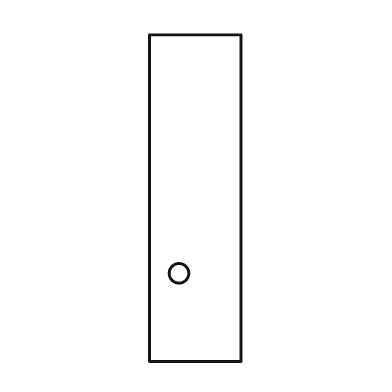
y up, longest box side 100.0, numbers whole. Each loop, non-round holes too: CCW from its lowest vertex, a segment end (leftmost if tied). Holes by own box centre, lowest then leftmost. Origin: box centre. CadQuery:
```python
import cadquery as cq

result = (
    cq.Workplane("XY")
    .moveTo(-14.0, -50.0)
    .lineTo(14.0, -50.0)
    .lineTo(14.0, 50.0)
    .lineTo(-14.0, 50.0)
    .close()
    .moveTo(-5.0, -23.0)
    .circle(3.0)
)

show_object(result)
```